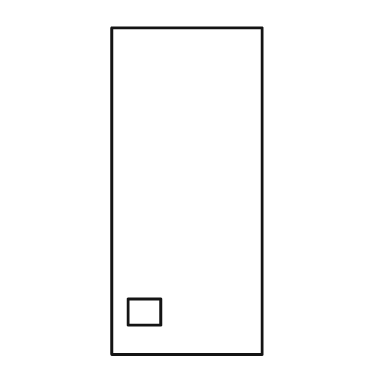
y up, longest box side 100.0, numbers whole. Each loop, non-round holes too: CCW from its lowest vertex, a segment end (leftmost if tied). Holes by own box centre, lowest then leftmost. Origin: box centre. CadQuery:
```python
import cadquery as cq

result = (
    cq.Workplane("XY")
    .moveTo(-23.0, -50.0)
    .lineTo(23.0, -50.0)
    .lineTo(23.0, 50.0)
    .lineTo(-23.0, 50.0)
    .close()
    .moveTo(-18.0, -41.0)
    .lineTo(-8.0, -41.0)
    .lineTo(-8.0, -33.0)
    .lineTo(-18.0, -33.0)
    .close()
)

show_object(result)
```